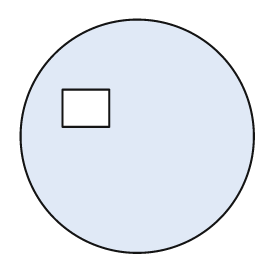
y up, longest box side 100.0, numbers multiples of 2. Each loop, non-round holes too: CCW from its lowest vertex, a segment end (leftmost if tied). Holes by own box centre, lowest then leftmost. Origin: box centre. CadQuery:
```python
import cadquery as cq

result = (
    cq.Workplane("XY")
    .moveTo(0.0, 0.0)
    .circle(50.0)
    .moveTo(-32.0, 4.0)
    .lineTo(-12.0, 4.0)
    .lineTo(-12.0, 20.0)
    .lineTo(-32.0, 20.0)
    .close()
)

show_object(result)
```